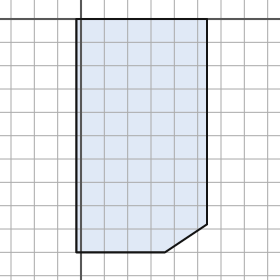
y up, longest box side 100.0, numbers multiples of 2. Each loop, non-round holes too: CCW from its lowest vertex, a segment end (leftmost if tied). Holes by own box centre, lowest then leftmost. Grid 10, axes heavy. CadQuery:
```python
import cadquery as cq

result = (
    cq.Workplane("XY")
    .moveTo(-2.0, -100.0)
    .lineTo(36.0, -100.0)
    .lineTo(54.0, -88.0)
    .lineTo(54.0, 0.0)
    .lineTo(-2.0, 0.0)
    .close()
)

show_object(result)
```